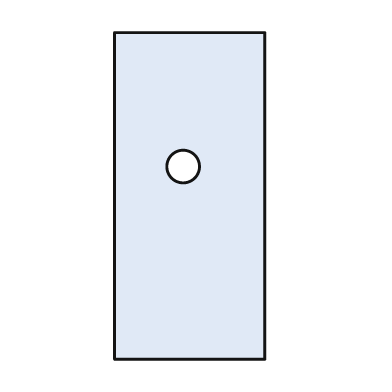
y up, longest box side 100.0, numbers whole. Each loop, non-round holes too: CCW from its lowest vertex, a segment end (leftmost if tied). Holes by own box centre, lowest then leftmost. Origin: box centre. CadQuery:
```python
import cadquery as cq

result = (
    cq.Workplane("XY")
    .moveTo(-23.0, -50.0)
    .lineTo(23.0, -50.0)
    .lineTo(23.0, 50.0)
    .lineTo(-23.0, 50.0)
    .close()
    .moveTo(-2.0, 9.0)
    .circle(5.0)
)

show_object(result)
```